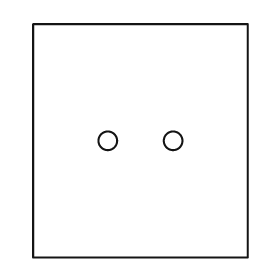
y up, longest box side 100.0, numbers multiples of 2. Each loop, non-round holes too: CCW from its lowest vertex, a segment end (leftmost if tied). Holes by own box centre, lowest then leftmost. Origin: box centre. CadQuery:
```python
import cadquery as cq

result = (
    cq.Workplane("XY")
    .moveTo(-46.0, -50.0)
    .lineTo(46.0, -50.0)
    .lineTo(46.0, 50.0)
    .lineTo(-46.0, 50.0)
    .close()
    .moveTo(-14.0, 0.0)
    .circle(4.0)
    .moveTo(14.0, 0.0)
    .circle(4.0)
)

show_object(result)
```